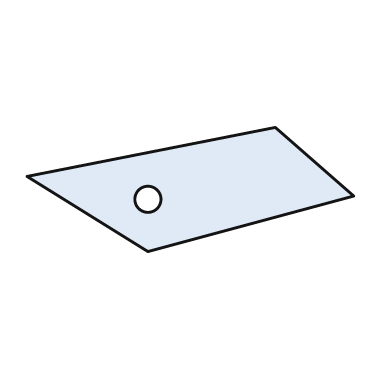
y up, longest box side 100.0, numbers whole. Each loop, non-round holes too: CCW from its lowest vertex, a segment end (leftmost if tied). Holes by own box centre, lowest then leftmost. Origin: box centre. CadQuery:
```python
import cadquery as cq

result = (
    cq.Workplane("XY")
    .moveTo(-13.0, -19.0)
    .lineTo(50.0, -2.0)
    .lineTo(26.0, 19.0)
    .lineTo(-50.0, 4.0)
    .close()
    .moveTo(-13.0, -3.0)
    .circle(4.0)
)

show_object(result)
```